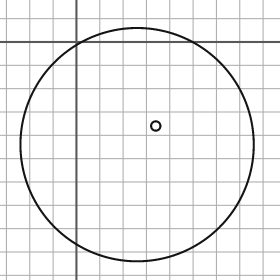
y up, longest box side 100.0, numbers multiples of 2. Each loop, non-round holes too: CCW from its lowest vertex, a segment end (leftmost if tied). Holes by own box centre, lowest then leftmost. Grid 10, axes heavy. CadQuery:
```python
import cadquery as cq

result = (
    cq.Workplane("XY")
    .moveTo(26.0, -44.0)
    .circle(50.0)
    .moveTo(34.0, -36.0)
    .circle(2.0)
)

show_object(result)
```